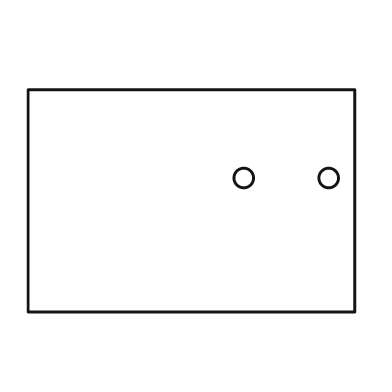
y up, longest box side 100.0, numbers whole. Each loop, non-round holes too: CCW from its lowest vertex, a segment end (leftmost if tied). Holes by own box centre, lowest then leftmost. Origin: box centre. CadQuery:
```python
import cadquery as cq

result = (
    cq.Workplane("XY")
    .moveTo(-50.0, -34.0)
    .lineTo(50.0, -34.0)
    .lineTo(50.0, 34.0)
    .lineTo(-50.0, 34.0)
    .close()
    .moveTo(16.0, 7.0)
    .circle(3.0)
    .moveTo(42.0, 7.0)
    .circle(3.0)
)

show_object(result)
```